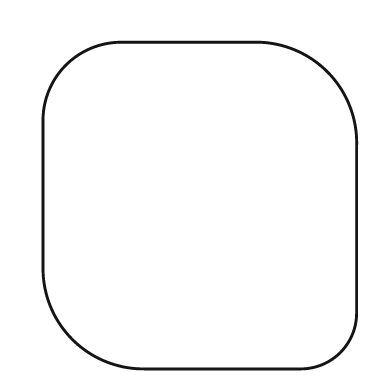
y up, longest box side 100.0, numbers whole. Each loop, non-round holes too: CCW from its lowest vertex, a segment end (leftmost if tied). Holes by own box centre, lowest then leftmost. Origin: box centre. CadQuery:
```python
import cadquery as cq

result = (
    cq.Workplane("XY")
    .moveTo(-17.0, -50.0)
    .lineTo(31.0, -50.0)
    .threePointArc((43.0, -45.0), (48.0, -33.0))
    .lineTo(48.0, 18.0)
    .threePointArc((39.0, 41.0), (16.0, 50.0))
    .lineTo(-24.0, 50.0)
    .threePointArc((-41.0, 43.0), (-48.0, 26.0))
    .lineTo(-48.0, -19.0)
    .threePointArc((-39.0, -41.0), (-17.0, -50.0))
    .close()
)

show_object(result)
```